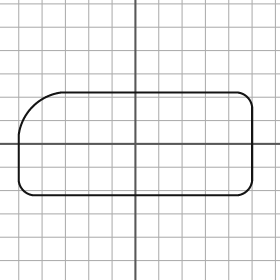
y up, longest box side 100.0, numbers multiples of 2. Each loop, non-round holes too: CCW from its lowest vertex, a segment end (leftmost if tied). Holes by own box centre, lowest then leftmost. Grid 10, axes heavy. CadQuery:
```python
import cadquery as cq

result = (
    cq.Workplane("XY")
    .moveTo(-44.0, -22.0)
    .lineTo(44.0, -22.0)
    .threePointArc((48.0, -20.0), (50.0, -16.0))
    .lineTo(50.0, 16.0)
    .threePointArc((48.0, 20.0), (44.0, 22.0))
    .lineTo(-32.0, 22.0)
    .threePointArc((-44.0, 16.0), (-50.0, 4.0))
    .lineTo(-50.0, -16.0)
    .threePointArc((-48.0, -20.0), (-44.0, -22.0))
    .close()
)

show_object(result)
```